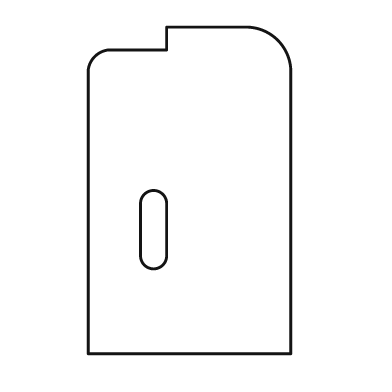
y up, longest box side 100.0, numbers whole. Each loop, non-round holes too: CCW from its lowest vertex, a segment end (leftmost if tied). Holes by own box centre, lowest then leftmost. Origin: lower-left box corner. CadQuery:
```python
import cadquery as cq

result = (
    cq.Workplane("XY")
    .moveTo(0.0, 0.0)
    .lineTo(62.0, 0.0)
    .lineTo(62.0, 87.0)
    .threePointArc((58.0, 96.0), (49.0, 100.0))
    .lineTo(24.0, 100.0)
    .lineTo(24.0, 93.0)
    .lineTo(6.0, 93.0)
    .threePointArc((2.0, 91.0), (0.0, 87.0))
    .close()
    .moveTo(16.0, 30.0)
    .threePointArc((20.0, 26.0), (24.0, 30.0))
    .lineTo(24.0, 46.0)
    .threePointArc((20.0, 50.0), (16.0, 46.0))
    .close()
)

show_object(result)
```